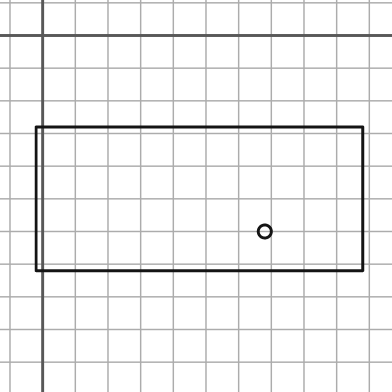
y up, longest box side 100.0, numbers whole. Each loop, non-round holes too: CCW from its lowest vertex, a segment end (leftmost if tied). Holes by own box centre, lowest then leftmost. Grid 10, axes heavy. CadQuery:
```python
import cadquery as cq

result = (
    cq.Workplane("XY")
    .moveTo(-2.0, -72.0)
    .lineTo(98.0, -72.0)
    .lineTo(98.0, -28.0)
    .lineTo(-2.0, -28.0)
    .close()
    .moveTo(68.0, -60.0)
    .circle(2.0)
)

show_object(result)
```